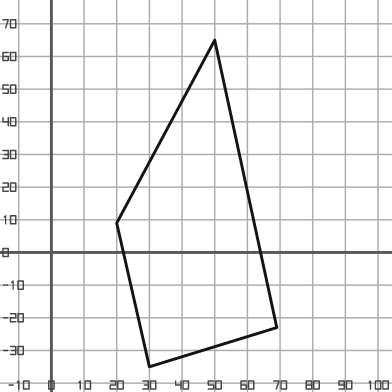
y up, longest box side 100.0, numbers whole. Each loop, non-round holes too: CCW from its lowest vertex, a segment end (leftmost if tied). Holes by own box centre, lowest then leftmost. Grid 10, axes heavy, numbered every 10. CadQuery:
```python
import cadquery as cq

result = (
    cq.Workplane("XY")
    .moveTo(30.0, -35.0)
    .lineTo(69.0, -23.0)
    .lineTo(50.0, 65.0)
    .lineTo(20.0, 9.0)
    .close()
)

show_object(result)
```